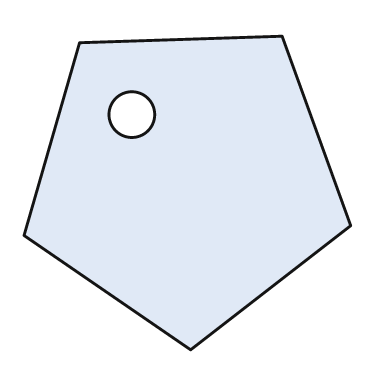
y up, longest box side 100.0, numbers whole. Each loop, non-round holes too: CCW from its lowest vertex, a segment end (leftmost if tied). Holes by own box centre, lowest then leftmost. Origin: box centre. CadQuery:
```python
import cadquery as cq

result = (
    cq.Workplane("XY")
    .moveTo(1.0, -48.0)
    .lineTo(50.0, -10.0)
    .lineTo(29.0, 48.0)
    .lineTo(-33.0, 46.0)
    .lineTo(-50.0, -13.0)
    .close()
    .moveTo(-17.0, 24.0)
    .circle(7.0)
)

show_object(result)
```